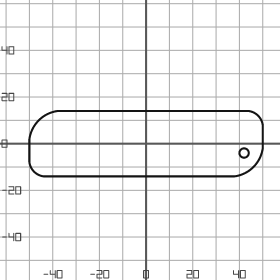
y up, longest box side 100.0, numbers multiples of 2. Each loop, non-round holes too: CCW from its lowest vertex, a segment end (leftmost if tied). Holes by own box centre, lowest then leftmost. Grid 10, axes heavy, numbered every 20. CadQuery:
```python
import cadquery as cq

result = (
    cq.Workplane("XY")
    .moveTo(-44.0, -14.0)
    .lineTo(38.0, -14.0)
    .threePointArc((46.0, -10.0), (50.0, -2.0))
    .lineTo(50.0, 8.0)
    .threePointArc((48.0, 12.0), (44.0, 14.0))
    .lineTo(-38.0, 14.0)
    .threePointArc((-46.0, 10.0), (-50.0, 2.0))
    .lineTo(-50.0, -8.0)
    .threePointArc((-48.0, -12.0), (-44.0, -14.0))
    .close()
    .moveTo(42.0, -4.0)
    .circle(2.0)
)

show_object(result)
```